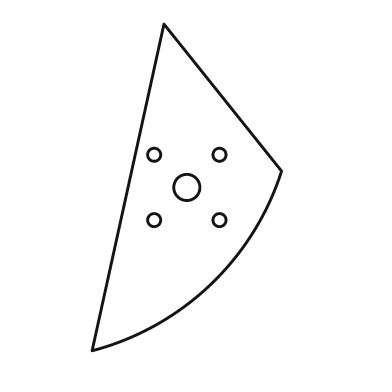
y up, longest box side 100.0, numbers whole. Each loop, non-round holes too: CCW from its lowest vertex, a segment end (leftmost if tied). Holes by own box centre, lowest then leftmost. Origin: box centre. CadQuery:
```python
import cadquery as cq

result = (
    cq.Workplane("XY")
    .moveTo(-29.0, -50.0)
    .threePointArc((7.0, -30.0), (29.0, 5.0))
    .lineTo(-7.0, 50.0)
    .close()
    .moveTo(-10.0, -10.0)
    .circle(2.0)
    .moveTo(10.0, -10.0)
    .circle(2.0)
    .moveTo(0.0, 0.0)
    .circle(4.0)
    .moveTo(-10.0, 10.0)
    .circle(2.0)
    .moveTo(10.0, 10.0)
    .circle(2.0)
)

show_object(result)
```